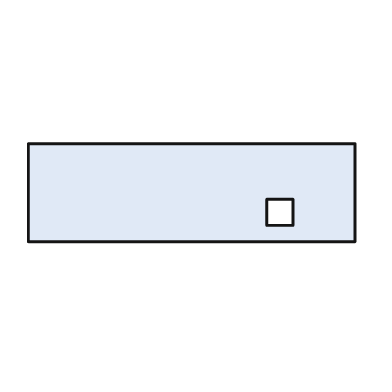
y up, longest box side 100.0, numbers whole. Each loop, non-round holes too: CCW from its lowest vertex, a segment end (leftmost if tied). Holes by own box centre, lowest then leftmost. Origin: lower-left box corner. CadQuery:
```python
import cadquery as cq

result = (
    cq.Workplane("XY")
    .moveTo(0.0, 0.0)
    .lineTo(100.0, 0.0)
    .lineTo(100.0, 30.0)
    .lineTo(0.0, 30.0)
    .close()
    .moveTo(73.0, 5.0)
    .lineTo(81.0, 5.0)
    .lineTo(81.0, 13.0)
    .lineTo(73.0, 13.0)
    .close()
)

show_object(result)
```